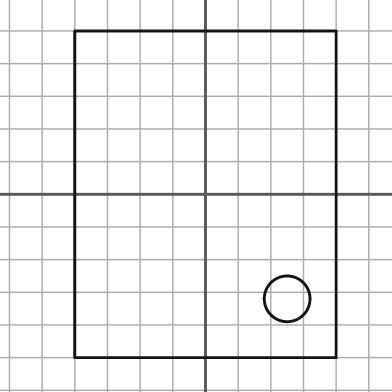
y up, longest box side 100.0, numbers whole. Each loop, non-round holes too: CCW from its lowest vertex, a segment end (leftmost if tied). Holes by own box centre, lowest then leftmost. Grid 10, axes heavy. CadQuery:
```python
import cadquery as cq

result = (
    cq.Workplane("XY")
    .moveTo(-40.0, -50.0)
    .lineTo(40.0, -50.0)
    .lineTo(40.0, 50.0)
    .lineTo(-40.0, 50.0)
    .close()
    .moveTo(25.0, -32.0)
    .circle(7.0)
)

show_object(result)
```